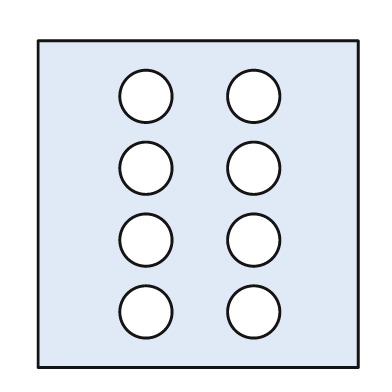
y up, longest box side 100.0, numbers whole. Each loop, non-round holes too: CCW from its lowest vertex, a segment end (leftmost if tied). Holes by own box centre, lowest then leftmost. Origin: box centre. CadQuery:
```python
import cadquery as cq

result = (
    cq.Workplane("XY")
    .moveTo(-49.0, -50.0)
    .lineTo(49.0, -50.0)
    .lineTo(49.0, 50.0)
    .lineTo(-49.0, 50.0)
    .close()
    .moveTo(-16.0, -33.0)
    .circle(8.0)
    .moveTo(17.0, -33.0)
    .circle(8.0)
    .moveTo(-16.0, -11.0)
    .circle(8.0)
    .moveTo(17.0, -11.0)
    .circle(8.0)
    .moveTo(-16.0, 11.0)
    .circle(8.0)
    .moveTo(17.0, 11.0)
    .circle(8.0)
    .moveTo(-16.0, 33.0)
    .circle(8.0)
    .moveTo(17.0, 33.0)
    .circle(8.0)
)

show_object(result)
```